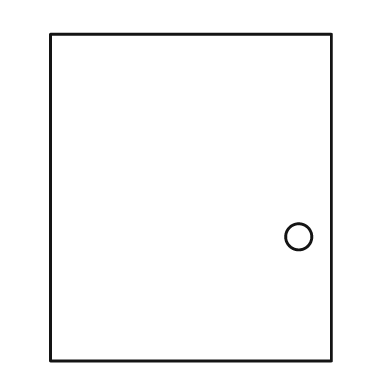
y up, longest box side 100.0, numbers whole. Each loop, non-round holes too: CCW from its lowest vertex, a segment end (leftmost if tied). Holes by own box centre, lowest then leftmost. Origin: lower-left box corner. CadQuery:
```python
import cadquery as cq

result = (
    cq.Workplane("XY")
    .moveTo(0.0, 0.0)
    .lineTo(86.0, 0.0)
    .lineTo(86.0, 100.0)
    .lineTo(0.0, 100.0)
    .close()
    .moveTo(76.0, 38.0)
    .circle(4.0)
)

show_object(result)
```